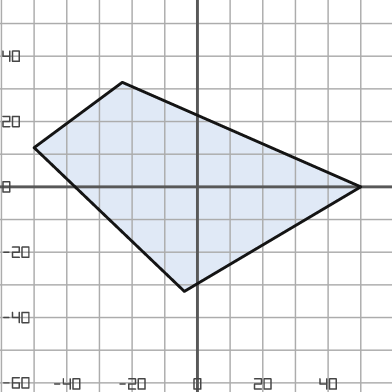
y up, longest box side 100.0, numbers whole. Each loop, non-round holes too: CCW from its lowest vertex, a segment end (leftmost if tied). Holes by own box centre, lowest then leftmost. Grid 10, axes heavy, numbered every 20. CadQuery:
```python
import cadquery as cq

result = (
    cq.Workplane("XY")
    .moveTo(-4.0, -32.0)
    .lineTo(50.0, 0.0)
    .lineTo(-23.0, 32.0)
    .lineTo(-50.0, 12.0)
    .close()
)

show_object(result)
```